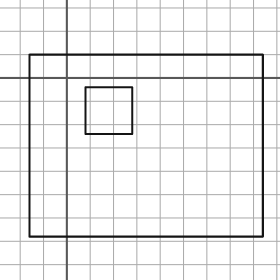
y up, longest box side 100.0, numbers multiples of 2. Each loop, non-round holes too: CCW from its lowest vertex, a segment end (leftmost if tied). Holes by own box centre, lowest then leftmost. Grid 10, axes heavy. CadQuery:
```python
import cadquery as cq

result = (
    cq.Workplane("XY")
    .moveTo(-16.0, -68.0)
    .lineTo(84.0, -68.0)
    .lineTo(84.0, 10.0)
    .lineTo(-16.0, 10.0)
    .close()
    .moveTo(8.0, -24.0)
    .lineTo(28.0, -24.0)
    .lineTo(28.0, -4.0)
    .lineTo(8.0, -4.0)
    .close()
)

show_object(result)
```